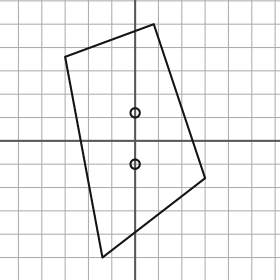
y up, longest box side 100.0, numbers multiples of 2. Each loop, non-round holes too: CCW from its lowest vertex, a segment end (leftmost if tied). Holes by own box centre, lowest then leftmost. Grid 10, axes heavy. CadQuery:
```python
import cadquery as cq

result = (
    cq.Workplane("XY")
    .moveTo(-14.0, -50.0)
    .lineTo(30.0, -16.0)
    .lineTo(8.0, 50.0)
    .lineTo(-30.0, 36.0)
    .close()
    .moveTo(0.0, -10.0)
    .circle(2.0)
    .moveTo(0.0, 12.0)
    .circle(2.0)
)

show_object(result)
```